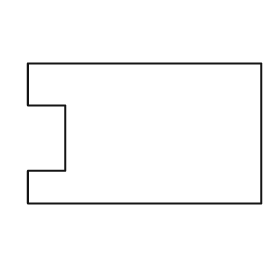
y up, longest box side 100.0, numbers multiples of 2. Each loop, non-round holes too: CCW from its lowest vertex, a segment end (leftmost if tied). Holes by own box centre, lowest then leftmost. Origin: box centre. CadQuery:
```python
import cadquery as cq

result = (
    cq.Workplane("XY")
    .moveTo(-50.0, -30.0)
    .lineTo(50.0, -30.0)
    .lineTo(50.0, 30.0)
    .lineTo(-50.0, 30.0)
    .lineTo(-50.0, 12.0)
    .lineTo(-34.0, 12.0)
    .lineTo(-34.0, -16.0)
    .lineTo(-50.0, -16.0)
    .close()
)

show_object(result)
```